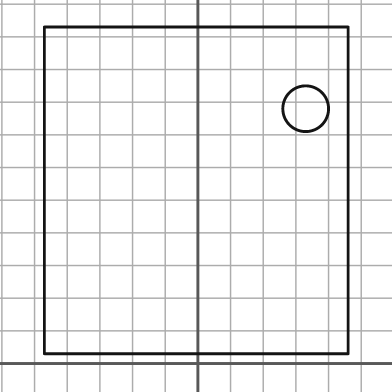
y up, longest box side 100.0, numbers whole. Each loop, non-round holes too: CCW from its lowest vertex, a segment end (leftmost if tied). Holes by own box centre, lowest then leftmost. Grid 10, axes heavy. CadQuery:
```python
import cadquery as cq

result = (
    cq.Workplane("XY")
    .moveTo(-47.0, 3.0)
    .lineTo(46.0, 3.0)
    .lineTo(46.0, 103.0)
    .lineTo(-47.0, 103.0)
    .close()
    .moveTo(33.0, 78.0)
    .circle(7.0)
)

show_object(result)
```